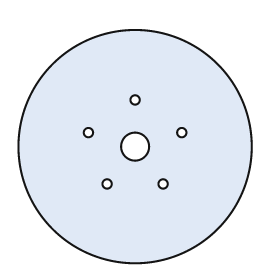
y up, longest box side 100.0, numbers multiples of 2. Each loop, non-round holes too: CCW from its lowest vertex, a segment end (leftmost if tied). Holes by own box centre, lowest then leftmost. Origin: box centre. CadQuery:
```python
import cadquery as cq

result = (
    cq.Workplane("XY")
    .moveTo(0.0, 0.0)
    .circle(50.0)
    .moveTo(-12.0, -16.0)
    .circle(2.0)
    .moveTo(12.0, -16.0)
    .circle(2.0)
    .moveTo(0.0, 0.0)
    .circle(6.0)
    .moveTo(-20.0, 6.0)
    .circle(2.0)
    .moveTo(20.0, 6.0)
    .circle(2.0)
    .moveTo(0.0, 20.0)
    .circle(2.0)
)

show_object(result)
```